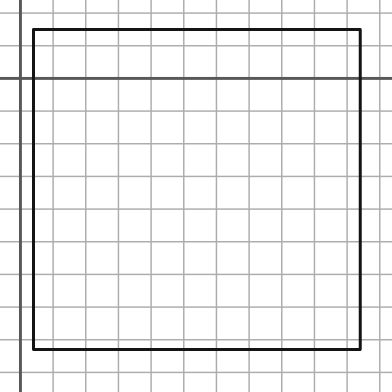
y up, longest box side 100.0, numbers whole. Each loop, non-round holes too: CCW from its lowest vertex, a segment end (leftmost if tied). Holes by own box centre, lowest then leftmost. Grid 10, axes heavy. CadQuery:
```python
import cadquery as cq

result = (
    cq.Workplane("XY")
    .moveTo(4.0, -83.0)
    .lineTo(104.0, -83.0)
    .lineTo(104.0, 15.0)
    .lineTo(4.0, 15.0)
    .close()
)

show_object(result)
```